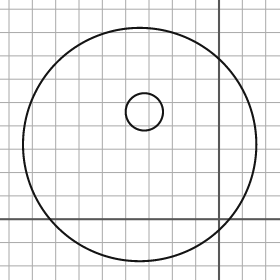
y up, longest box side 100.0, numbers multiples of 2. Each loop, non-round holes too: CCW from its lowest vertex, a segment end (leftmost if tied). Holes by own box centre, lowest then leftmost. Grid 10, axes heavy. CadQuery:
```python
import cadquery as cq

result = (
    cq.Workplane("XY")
    .moveTo(-34.0, 32.0)
    .circle(50.0)
    .moveTo(-32.0, 46.0)
    .circle(8.0)
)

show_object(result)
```